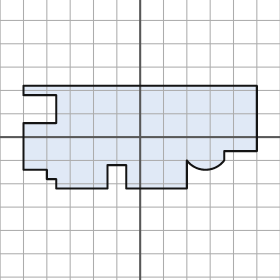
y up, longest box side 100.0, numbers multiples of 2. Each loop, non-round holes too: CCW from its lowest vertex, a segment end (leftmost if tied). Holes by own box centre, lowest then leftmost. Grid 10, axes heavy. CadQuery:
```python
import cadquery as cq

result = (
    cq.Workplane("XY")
    .moveTo(-36.0, -22.0)
    .lineTo(-14.0, -22.0)
    .lineTo(-14.0, -12.0)
    .lineTo(-6.0, -12.0)
    .lineTo(-6.0, -22.0)
    .lineTo(20.0, -22.0)
    .lineTo(20.0, -10.0)
    .threePointArc((28.0, -14.0), (36.0, -10.0))
    .lineTo(36.0, -6.0)
    .lineTo(50.0, -6.0)
    .lineTo(50.0, 22.0)
    .lineTo(-50.0, 22.0)
    .lineTo(-50.0, 18.0)
    .lineTo(-36.0, 18.0)
    .lineTo(-36.0, 6.0)
    .lineTo(-50.0, 6.0)
    .lineTo(-50.0, -14.0)
    .lineTo(-40.0, -14.0)
    .lineTo(-40.0, -18.0)
    .lineTo(-36.0, -18.0)
    .close()
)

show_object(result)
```